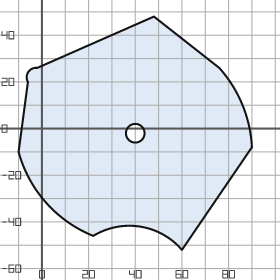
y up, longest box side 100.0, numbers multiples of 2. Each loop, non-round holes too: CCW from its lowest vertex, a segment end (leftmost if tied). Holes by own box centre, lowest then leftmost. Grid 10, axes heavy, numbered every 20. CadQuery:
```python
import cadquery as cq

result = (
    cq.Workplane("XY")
    .moveTo(60.0, -52.0)
    .lineTo(90.0, -8.0)
    .threePointArc((86.0, 10.0), (76.0, 26.0))
    .lineTo(48.0, 48.0)
    .lineTo(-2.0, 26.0)
    .threePointArc((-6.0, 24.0), (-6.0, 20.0))
    .lineTo(-10.0, -10.0)
    .threePointArc((2.0, -32.0), (22.0, -46.0))
    .threePointArc((42.0, -42.0), (60.0, -52.0))
    .close()
    .moveTo(40.0, -2.0)
    .circle(4.0)
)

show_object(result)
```